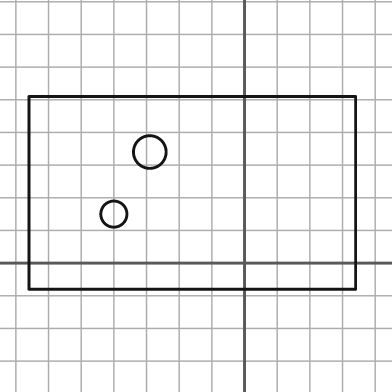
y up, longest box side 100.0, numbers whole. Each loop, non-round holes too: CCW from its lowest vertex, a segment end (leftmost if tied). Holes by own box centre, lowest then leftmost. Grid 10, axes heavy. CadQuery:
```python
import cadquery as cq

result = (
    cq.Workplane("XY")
    .moveTo(-66.0, -8.0)
    .lineTo(34.0, -8.0)
    .lineTo(34.0, 51.0)
    .lineTo(-66.0, 51.0)
    .close()
    .moveTo(-40.0, 15.0)
    .circle(4.0)
    .moveTo(-29.0, 34.0)
    .circle(5.0)
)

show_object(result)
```